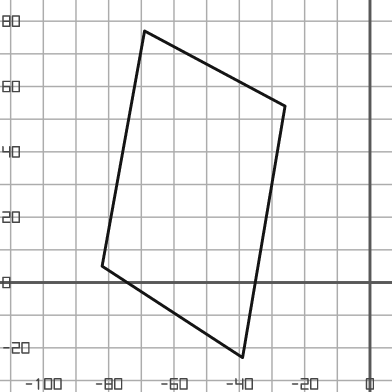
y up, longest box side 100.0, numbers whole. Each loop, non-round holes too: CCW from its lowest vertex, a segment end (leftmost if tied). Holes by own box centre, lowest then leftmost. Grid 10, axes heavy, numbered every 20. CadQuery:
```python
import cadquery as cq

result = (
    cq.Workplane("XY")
    .moveTo(-39.0, -23.0)
    .lineTo(-26.0, 54.0)
    .lineTo(-69.0, 77.0)
    .lineTo(-82.0, 5.0)
    .close()
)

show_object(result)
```